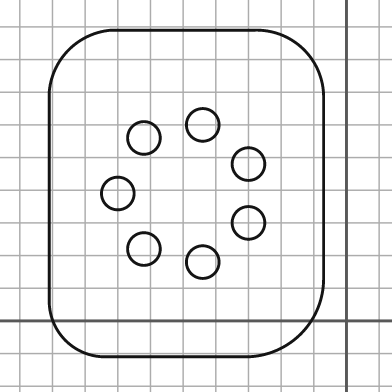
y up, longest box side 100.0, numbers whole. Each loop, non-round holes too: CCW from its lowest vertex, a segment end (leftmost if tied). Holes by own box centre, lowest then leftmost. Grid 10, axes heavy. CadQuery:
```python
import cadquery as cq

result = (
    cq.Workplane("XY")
    .moveTo(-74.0, -11.0)
    .lineTo(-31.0, -11.0)
    .threePointArc((-14.0, -4.0), (-7.0, 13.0))
    .lineTo(-7.0, 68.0)
    .threePointArc((-13.0, 83.0), (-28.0, 89.0))
    .lineTo(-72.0, 89.0)
    .threePointArc((-85.0, 83.0), (-91.0, 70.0))
    .lineTo(-91.0, 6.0)
    .threePointArc((-86.0, -6.0), (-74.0, -11.0))
    .close()
    .moveTo(-44.0, 18.0)
    .circle(5.0)
    .moveTo(-62.0, 22.0)
    .circle(5.0)
    .moveTo(-30.0, 30.0)
    .circle(5.0)
    .moveTo(-70.0, 39.0)
    .circle(5.0)
    .moveTo(-30.0, 48.0)
    .circle(5.0)
    .moveTo(-62.0, 56.0)
    .circle(5.0)
    .moveTo(-44.0, 60.0)
    .circle(5.0)
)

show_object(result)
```